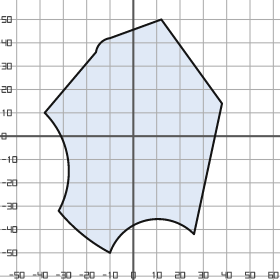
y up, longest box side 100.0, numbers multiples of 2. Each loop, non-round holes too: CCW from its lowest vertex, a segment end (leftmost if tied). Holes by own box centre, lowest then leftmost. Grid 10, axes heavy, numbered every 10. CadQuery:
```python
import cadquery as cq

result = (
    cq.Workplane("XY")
    .moveTo(-10.0, -50.0)
    .threePointArc((6.0, -36.0), (26.0, -42.0))
    .lineTo(38.0, 14.0)
    .lineTo(12.0, 50.0)
    .lineTo(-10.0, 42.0)
    .threePointArc((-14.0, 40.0), (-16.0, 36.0))
    .lineTo(-38.0, 10.0)
    .threePointArc((-28.0, -10.0), (-32.0, -32.0))
    .threePointArc((-22.0, -42.0), (-10.0, -50.0))
    .close()
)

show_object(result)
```